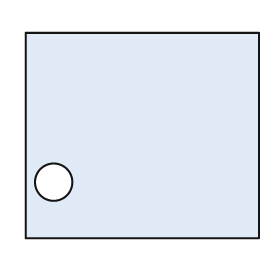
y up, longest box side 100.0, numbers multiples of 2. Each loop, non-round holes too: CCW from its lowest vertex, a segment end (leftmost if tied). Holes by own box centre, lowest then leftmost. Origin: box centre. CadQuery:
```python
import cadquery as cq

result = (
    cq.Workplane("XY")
    .moveTo(-50.0, -44.0)
    .lineTo(50.0, -44.0)
    .lineTo(50.0, 44.0)
    .lineTo(-50.0, 44.0)
    .close()
    .moveTo(-38.0, -20.0)
    .circle(8.0)
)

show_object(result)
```